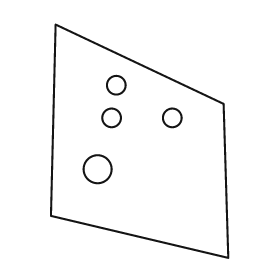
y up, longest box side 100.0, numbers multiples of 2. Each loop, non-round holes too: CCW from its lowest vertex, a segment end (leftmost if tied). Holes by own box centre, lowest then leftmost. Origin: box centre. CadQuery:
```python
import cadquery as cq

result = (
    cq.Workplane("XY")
    .moveTo(38.0, -50.0)
    .lineTo(36.0, 16.0)
    .lineTo(-36.0, 50.0)
    .lineTo(-38.0, -32.0)
    .close()
    .moveTo(-18.0, -12.0)
    .circle(6.0)
    .moveTo(-12.0, 10.0)
    .circle(4.0)
    .moveTo(14.0, 10.0)
    .circle(4.0)
    .moveTo(-10.0, 24.0)
    .circle(4.0)
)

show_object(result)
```